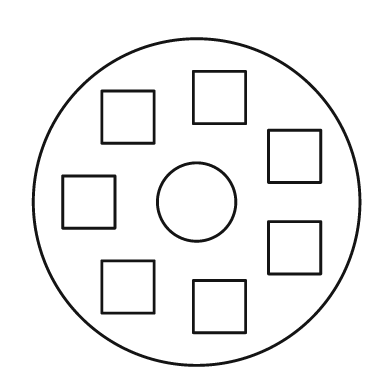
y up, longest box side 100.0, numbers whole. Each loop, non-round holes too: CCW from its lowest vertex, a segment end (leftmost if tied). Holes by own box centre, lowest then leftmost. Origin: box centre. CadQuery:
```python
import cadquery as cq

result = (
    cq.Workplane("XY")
    .moveTo(0.0, 0.0)
    .circle(50.0)
    .moveTo(-1.0, -40.0)
    .lineTo(15.0, -40.0)
    .lineTo(15.0, -24.0)
    .lineTo(-1.0, -24.0)
    .close()
    .moveTo(-29.0, -34.0)
    .lineTo(-13.0, -34.0)
    .lineTo(-13.0, -18.0)
    .lineTo(-29.0, -18.0)
    .close()
    .moveTo(22.0, -22.0)
    .lineTo(38.0, -22.0)
    .lineTo(38.0, -6.0)
    .lineTo(22.0, -6.0)
    .close()
    .moveTo(-41.0, -8.0)
    .lineTo(-25.0, -8.0)
    .lineTo(-25.0, 8.0)
    .lineTo(-41.0, 8.0)
    .close()
    .moveTo(0.0, 0.0)
    .circle(12.0)
    .moveTo(22.0, 6.0)
    .lineTo(38.0, 6.0)
    .lineTo(38.0, 22.0)
    .lineTo(22.0, 22.0)
    .close()
    .moveTo(-29.0, 18.0)
    .lineTo(-13.0, 18.0)
    .lineTo(-13.0, 34.0)
    .lineTo(-29.0, 34.0)
    .close()
    .moveTo(-1.0, 24.0)
    .lineTo(15.0, 24.0)
    .lineTo(15.0, 40.0)
    .lineTo(-1.0, 40.0)
    .close()
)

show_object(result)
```